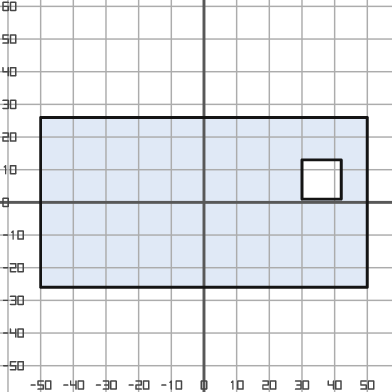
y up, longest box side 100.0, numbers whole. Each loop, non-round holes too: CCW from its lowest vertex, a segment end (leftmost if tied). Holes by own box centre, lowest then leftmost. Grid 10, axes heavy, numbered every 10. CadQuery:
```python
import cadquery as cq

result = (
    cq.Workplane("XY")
    .moveTo(-50.0, -26.0)
    .lineTo(50.0, -26.0)
    .lineTo(50.0, 26.0)
    .lineTo(-50.0, 26.0)
    .close()
    .moveTo(30.0, 1.0)
    .lineTo(42.0, 1.0)
    .lineTo(42.0, 13.0)
    .lineTo(30.0, 13.0)
    .close()
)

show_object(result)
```